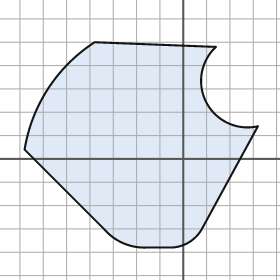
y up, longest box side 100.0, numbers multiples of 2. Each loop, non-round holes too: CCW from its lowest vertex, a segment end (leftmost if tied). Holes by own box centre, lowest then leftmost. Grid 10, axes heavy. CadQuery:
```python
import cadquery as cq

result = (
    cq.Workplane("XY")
    .moveTo(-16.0, -38.0)
    .lineTo(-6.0, -38.0)
    .threePointArc((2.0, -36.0), (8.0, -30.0))
    .lineTo(32.0, 14.0)
    .threePointArc((10.0, 24.0), (14.0, 48.0))
    .lineTo(-38.0, 50.0)
    .threePointArc((-58.0, 30.0), (-68.0, 4.0))
    .lineTo(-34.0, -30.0)
    .threePointArc((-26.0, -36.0), (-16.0, -38.0))
    .close()
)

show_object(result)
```